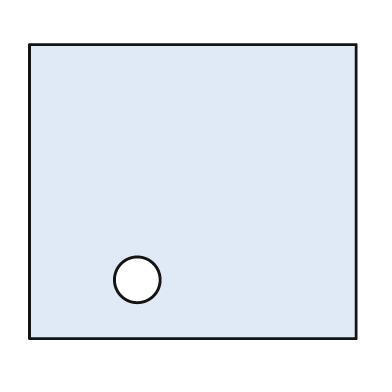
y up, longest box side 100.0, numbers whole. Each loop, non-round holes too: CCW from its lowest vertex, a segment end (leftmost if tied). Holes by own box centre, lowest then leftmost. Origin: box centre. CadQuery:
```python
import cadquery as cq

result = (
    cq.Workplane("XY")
    .moveTo(-50.0, -45.0)
    .lineTo(50.0, -45.0)
    .lineTo(50.0, 45.0)
    .lineTo(-50.0, 45.0)
    .close()
    .moveTo(-17.0, -27.0)
    .circle(7.0)
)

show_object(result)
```